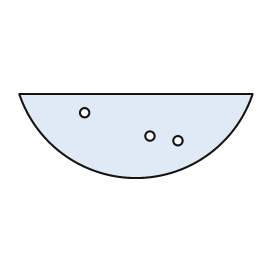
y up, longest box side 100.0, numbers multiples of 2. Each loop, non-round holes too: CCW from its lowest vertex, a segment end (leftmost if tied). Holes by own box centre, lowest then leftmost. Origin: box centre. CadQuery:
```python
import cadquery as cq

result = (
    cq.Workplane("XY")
    .moveTo(-50.0, 18.0)
    .threePointArc((0.0, -18.0), (50.0, 18.0))
    .close()
    .moveTo(18.0, -2.0)
    .circle(2.0)
    .moveTo(6.0, 0.0)
    .circle(2.0)
    .moveTo(-22.0, 10.0)
    .circle(2.0)
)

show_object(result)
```